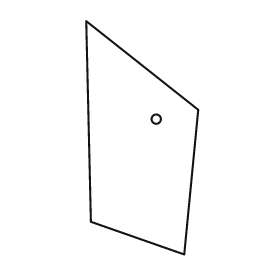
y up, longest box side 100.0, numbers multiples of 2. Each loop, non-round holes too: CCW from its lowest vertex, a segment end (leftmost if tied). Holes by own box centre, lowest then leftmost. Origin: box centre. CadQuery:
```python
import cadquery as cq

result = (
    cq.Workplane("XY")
    .moveTo(18.0, -50.0)
    .lineTo(24.0, 12.0)
    .lineTo(-24.0, 50.0)
    .lineTo(-22.0, -36.0)
    .close()
    .moveTo(6.0, 8.0)
    .circle(2.0)
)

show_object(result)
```